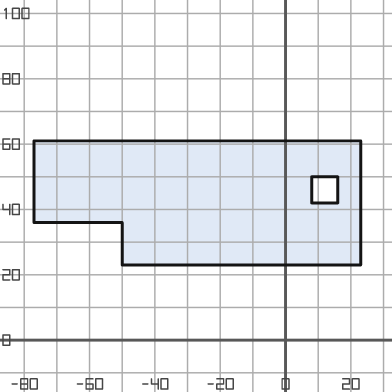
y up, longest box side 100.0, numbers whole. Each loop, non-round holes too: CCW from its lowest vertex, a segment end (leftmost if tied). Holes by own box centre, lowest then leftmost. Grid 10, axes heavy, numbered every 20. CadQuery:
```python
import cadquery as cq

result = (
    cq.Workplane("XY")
    .moveTo(-50.0, 23.0)
    .lineTo(23.0, 23.0)
    .lineTo(23.0, 61.0)
    .lineTo(-77.0, 61.0)
    .lineTo(-77.0, 36.0)
    .lineTo(-50.0, 36.0)
    .close()
    .moveTo(8.0, 42.0)
    .lineTo(16.0, 42.0)
    .lineTo(16.0, 50.0)
    .lineTo(8.0, 50.0)
    .close()
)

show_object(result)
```